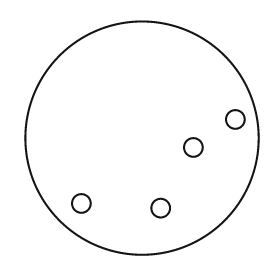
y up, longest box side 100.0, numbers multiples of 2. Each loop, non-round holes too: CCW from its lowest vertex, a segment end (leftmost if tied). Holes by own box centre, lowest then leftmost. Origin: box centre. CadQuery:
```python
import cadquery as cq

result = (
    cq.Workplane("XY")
    .moveTo(0.0, 0.0)
    .circle(50.0)
    .moveTo(8.0, -30.0)
    .circle(4.0)
    .moveTo(-26.0, -28.0)
    .circle(4.0)
    .moveTo(22.0, -4.0)
    .circle(4.0)
    .moveTo(40.0, 8.0)
    .circle(4.0)
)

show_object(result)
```